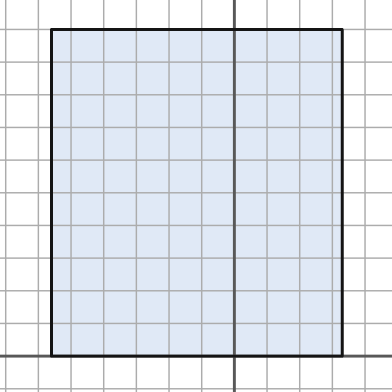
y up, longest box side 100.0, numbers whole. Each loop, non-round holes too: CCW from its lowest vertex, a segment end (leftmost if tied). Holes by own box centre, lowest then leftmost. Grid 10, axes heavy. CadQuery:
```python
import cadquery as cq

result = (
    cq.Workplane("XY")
    .moveTo(-56.0, 0.0)
    .lineTo(33.0, 0.0)
    .lineTo(33.0, 100.0)
    .lineTo(-56.0, 100.0)
    .close()
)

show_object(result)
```